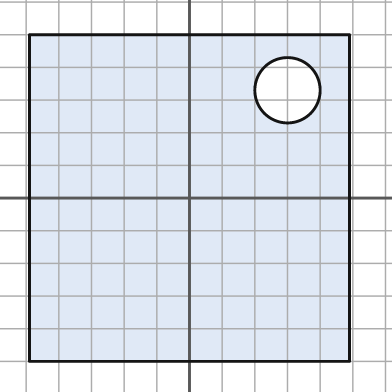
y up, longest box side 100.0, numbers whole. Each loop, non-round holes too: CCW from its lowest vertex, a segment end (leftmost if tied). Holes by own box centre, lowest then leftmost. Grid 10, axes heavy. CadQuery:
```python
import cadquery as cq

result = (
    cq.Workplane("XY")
    .moveTo(-49.0, -50.0)
    .lineTo(49.0, -50.0)
    .lineTo(49.0, 50.0)
    .lineTo(-49.0, 50.0)
    .close()
    .moveTo(30.0, 33.0)
    .circle(10.0)
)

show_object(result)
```